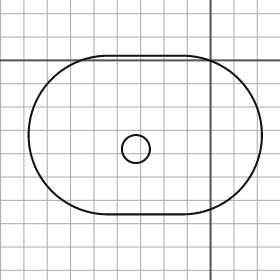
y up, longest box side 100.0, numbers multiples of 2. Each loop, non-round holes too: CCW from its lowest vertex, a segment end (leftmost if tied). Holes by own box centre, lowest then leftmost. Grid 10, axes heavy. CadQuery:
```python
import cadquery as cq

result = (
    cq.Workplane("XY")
    .moveTo(-44.0, -66.0)
    .lineTo(-12.0, -66.0)
    .threePointArc((22.0, -32.0), (-12.0, 2.0))
    .lineTo(-44.0, 2.0)
    .threePointArc((-78.0, -32.0), (-44.0, -66.0))
    .close()
    .moveTo(-32.0, -38.0)
    .circle(6.0)
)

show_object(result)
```